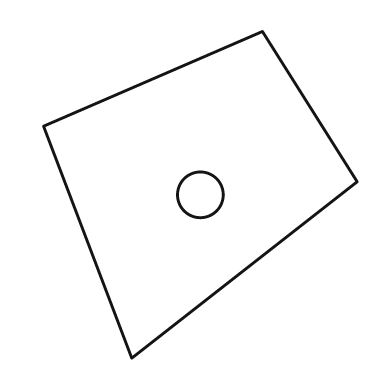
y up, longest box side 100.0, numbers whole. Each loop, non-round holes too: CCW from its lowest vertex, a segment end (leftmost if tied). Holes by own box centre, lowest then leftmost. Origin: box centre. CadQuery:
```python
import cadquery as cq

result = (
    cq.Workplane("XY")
    .moveTo(-21.0, -50.0)
    .lineTo(48.0, 4.0)
    .lineTo(19.0, 50.0)
    .lineTo(-48.0, 21.0)
    .close()
    .moveTo(0.0, 0.0)
    .circle(7.0)
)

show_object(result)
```